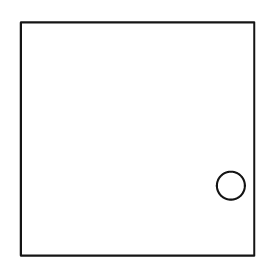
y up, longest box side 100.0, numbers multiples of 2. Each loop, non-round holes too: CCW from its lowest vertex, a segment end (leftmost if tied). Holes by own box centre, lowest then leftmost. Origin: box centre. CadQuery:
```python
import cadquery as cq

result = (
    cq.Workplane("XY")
    .moveTo(-50.0, -50.0)
    .lineTo(50.0, -50.0)
    .lineTo(50.0, 50.0)
    .lineTo(-50.0, 50.0)
    .close()
    .moveTo(40.0, -20.0)
    .circle(6.0)
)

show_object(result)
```